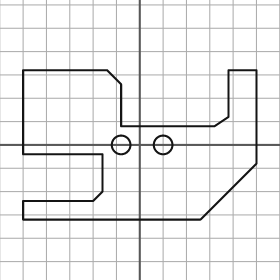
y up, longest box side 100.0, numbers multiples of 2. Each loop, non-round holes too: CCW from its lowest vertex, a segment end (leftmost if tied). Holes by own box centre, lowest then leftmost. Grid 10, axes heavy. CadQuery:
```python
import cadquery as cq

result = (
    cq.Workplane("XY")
    .moveTo(-50.0, -32.0)
    .lineTo(26.0, -32.0)
    .lineTo(50.0, -8.0)
    .lineTo(50.0, 32.0)
    .lineTo(38.0, 32.0)
    .lineTo(38.0, 12.0)
    .lineTo(32.0, 8.0)
    .lineTo(-8.0, 8.0)
    .lineTo(-8.0, 26.0)
    .lineTo(-14.0, 32.0)
    .lineTo(-50.0, 32.0)
    .lineTo(-50.0, -4.0)
    .lineTo(-16.0, -4.0)
    .lineTo(-16.0, -20.0)
    .lineTo(-20.0, -24.0)
    .lineTo(-50.0, -24.0)
    .close()
    .moveTo(-8.0, 0.0)
    .circle(4.0)
    .moveTo(10.0, 0.0)
    .circle(4.0)
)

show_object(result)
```